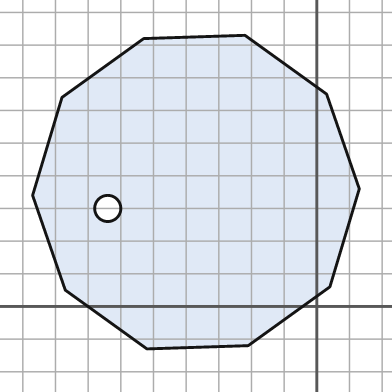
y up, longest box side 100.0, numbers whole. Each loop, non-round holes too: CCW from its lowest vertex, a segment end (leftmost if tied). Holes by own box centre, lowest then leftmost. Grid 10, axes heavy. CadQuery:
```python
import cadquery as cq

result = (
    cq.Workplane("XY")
    .moveTo(-52.0, -13.0)
    .lineTo(-21.0, -12.0)
    .lineTo(4.0, 6.0)
    .lineTo(13.0, 36.0)
    .lineTo(3.0, 65.0)
    .lineTo(-22.0, 83.0)
    .lineTo(-53.0, 82.0)
    .lineTo(-78.0, 64.0)
    .lineTo(-87.0, 34.0)
    .lineTo(-77.0, 5.0)
    .close()
    .moveTo(-64.0, 30.0)
    .circle(4.0)
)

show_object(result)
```